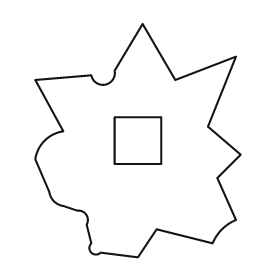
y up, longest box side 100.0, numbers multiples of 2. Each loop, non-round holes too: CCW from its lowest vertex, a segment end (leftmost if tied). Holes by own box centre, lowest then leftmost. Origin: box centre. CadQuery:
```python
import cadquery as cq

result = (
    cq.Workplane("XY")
    .moveTo(0.0, -50.0)
    .lineTo(8.0, -38.0)
    .lineTo(32.0, -44.0)
    .threePointArc((36.0, -38.0), (42.0, -34.0))
    .lineTo(34.0, -16.0)
    .lineTo(44.0, -6.0)
    .lineTo(30.0, 6.0)
    .lineTo(42.0, 36.0)
    .lineTo(16.0, 26.0)
    .lineTo(2.0, 50.0)
    .lineTo(-10.0, 30.0)
    .threePointArc((-14.0, 24.0), (-20.0, 28.0))
    .lineTo(-44.0, 26.0)
    .lineTo(-32.0, 4.0)
    .threePointArc((-40.0, 0.0), (-44.0, -8.0))
    .lineTo(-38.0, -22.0)
    .threePointArc((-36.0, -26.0), (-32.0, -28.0))
    .lineTo(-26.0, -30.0)
    .threePointArc((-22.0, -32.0), (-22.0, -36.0))
    .lineTo(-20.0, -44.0)
    .threePointArc((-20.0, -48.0), (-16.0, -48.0))
    .close()
    .moveTo(-10.0, -10.0)
    .lineTo(10.0, -10.0)
    .lineTo(10.0, 10.0)
    .lineTo(-10.0, 10.0)
    .close()
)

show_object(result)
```